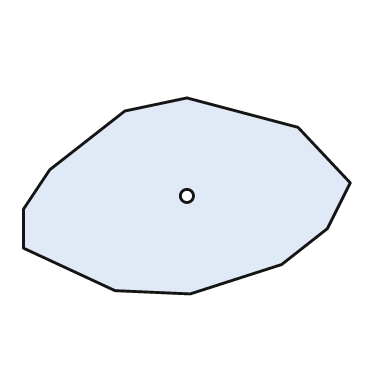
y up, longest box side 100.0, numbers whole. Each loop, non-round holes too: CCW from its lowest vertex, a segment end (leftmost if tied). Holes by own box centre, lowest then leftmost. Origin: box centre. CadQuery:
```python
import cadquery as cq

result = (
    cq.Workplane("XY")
    .moveTo(1.0, -30.0)
    .lineTo(29.0, -21.0)
    .lineTo(43.0, -10.0)
    .lineTo(50.0, 4.0)
    .lineTo(34.0, 21.0)
    .lineTo(0.0, 30.0)
    .lineTo(-19.0, 26.0)
    .lineTo(-42.0, 8.0)
    .lineTo(-50.0, -4.0)
    .lineTo(-50.0, -16.0)
    .lineTo(-22.0, -29.0)
    .close()
    .moveTo(0.0, 0.0)
    .circle(2.0)
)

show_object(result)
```